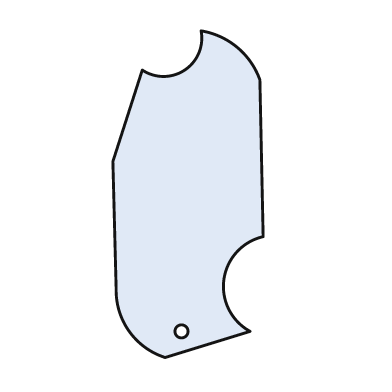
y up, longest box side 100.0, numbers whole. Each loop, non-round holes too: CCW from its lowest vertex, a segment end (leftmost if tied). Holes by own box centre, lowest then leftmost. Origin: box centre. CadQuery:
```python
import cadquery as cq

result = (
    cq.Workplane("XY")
    .moveTo(-7.0, -50.0)
    .lineTo(19.0, -42.0)
    .threePointArc((11.0, -26.0), (23.0, -13.0))
    .lineTo(22.0, 35.0)
    .threePointArc((15.0, 45.0), (4.0, 50.0))
    .threePointArc((-1.0, 38.0), (-14.0, 38.0))
    .lineTo(-23.0, 10.0)
    .lineTo(-22.0, -29.0)
    .threePointArc((-18.0, -42.0), (-7.0, -50.0))
    .close()
    .moveTo(-2.0, -42.0)
    .circle(2.0)
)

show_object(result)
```